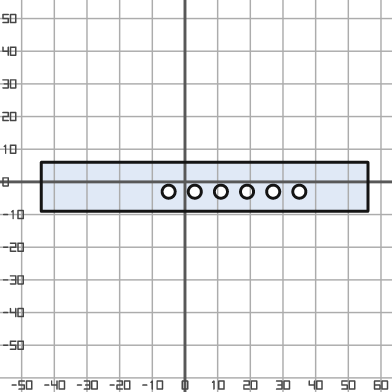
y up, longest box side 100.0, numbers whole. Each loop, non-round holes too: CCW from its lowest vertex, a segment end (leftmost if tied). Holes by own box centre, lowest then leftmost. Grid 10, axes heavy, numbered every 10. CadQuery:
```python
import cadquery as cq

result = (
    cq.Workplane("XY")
    .moveTo(-44.0, -9.0)
    .lineTo(56.0, -9.0)
    .lineTo(56.0, 6.0)
    .lineTo(-44.0, 6.0)
    .close()
    .moveTo(-5.0, -3.0)
    .circle(2.0)
    .moveTo(3.0, -3.0)
    .circle(2.0)
    .moveTo(11.0, -3.0)
    .circle(2.0)
    .moveTo(19.0, -3.0)
    .circle(2.0)
    .moveTo(27.0, -3.0)
    .circle(2.0)
    .moveTo(35.0, -3.0)
    .circle(2.0)
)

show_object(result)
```